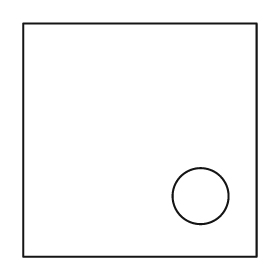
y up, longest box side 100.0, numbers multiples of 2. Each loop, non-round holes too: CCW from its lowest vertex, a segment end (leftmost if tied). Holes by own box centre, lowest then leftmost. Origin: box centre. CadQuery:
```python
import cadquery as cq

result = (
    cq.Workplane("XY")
    .moveTo(-50.0, -50.0)
    .lineTo(50.0, -50.0)
    .lineTo(50.0, 50.0)
    .lineTo(-50.0, 50.0)
    .close()
    .moveTo(26.0, -24.0)
    .circle(12.0)
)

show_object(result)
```